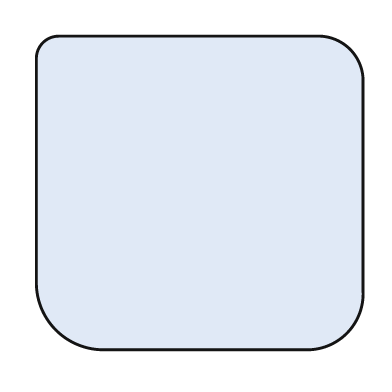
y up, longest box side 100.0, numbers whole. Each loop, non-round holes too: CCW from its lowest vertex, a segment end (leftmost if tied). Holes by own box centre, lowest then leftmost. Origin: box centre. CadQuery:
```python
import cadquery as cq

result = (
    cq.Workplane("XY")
    .moveTo(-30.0, -48.0)
    .lineTo(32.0, -48.0)
    .threePointArc((45.0, -43.0), (50.0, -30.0))
    .lineTo(50.0, 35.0)
    .threePointArc((46.0, 44.0), (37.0, 48.0))
    .lineTo(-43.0, 48.0)
    .threePointArc((-48.0, 46.0), (-50.0, 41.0))
    .lineTo(-50.0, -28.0)
    .threePointArc((-44.0, -42.0), (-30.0, -48.0))
    .close()
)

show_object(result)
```